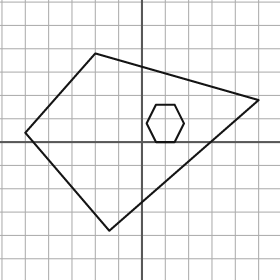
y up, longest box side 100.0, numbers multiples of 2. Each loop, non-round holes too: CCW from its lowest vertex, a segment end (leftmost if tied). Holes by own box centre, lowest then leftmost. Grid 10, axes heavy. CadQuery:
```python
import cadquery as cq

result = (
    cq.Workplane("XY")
    .moveTo(-14.0, -38.0)
    .lineTo(50.0, 18.0)
    .lineTo(-20.0, 38.0)
    .lineTo(-50.0, 4.0)
    .close()
    .moveTo(6.0, 0.0)
    .lineTo(14.0, 0.0)
    .lineTo(18.0, 8.0)
    .lineTo(14.0, 16.0)
    .lineTo(6.0, 16.0)
    .lineTo(2.0, 8.0)
    .close()
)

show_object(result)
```